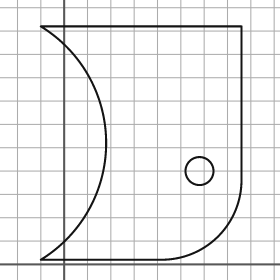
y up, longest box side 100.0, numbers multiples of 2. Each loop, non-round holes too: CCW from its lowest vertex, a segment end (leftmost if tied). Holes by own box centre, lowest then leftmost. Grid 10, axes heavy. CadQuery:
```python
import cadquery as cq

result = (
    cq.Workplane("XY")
    .moveTo(-10.0, 2.0)
    .lineTo(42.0, 2.0)
    .threePointArc((66.0, 12.0), (76.0, 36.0))
    .lineTo(76.0, 102.0)
    .lineTo(-10.0, 102.0)
    .threePointArc((18.0, 52.0), (-10.0, 2.0))
    .close()
    .moveTo(58.0, 40.0)
    .circle(6.0)
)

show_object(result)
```